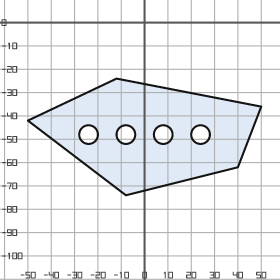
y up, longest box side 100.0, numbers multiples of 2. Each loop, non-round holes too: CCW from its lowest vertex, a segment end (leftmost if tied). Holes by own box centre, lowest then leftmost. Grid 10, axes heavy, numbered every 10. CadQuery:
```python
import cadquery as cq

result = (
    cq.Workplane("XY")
    .moveTo(-8.0, -74.0)
    .lineTo(40.0, -62.0)
    .lineTo(50.0, -36.0)
    .lineTo(-12.0, -24.0)
    .lineTo(-50.0, -42.0)
    .close()
    .moveTo(-24.0, -48.0)
    .circle(4.0)
    .moveTo(-8.0, -48.0)
    .circle(4.0)
    .moveTo(8.0, -48.0)
    .circle(4.0)
    .moveTo(24.0, -48.0)
    .circle(4.0)
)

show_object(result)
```